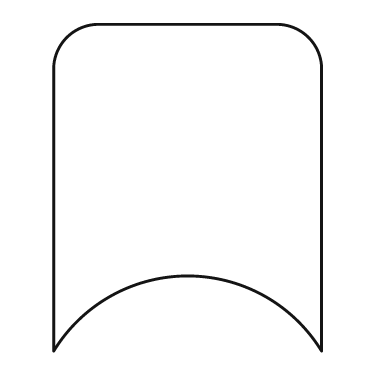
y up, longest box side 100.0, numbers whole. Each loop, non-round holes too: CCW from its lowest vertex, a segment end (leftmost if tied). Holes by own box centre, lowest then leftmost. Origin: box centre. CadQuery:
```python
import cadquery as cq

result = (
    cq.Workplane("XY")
    .moveTo(-41.0, -50.0)
    .threePointArc((0.0, -27.0), (41.0, -50.0))
    .lineTo(41.0, 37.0)
    .threePointArc((37.0, 46.0), (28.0, 50.0))
    .lineTo(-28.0, 50.0)
    .threePointArc((-37.0, 46.0), (-41.0, 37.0))
    .close()
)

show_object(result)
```